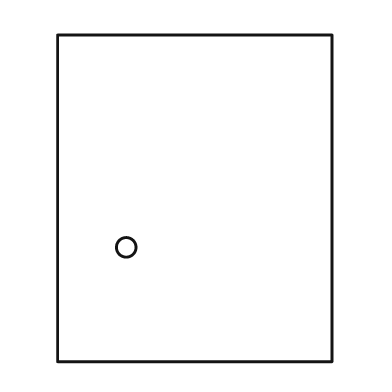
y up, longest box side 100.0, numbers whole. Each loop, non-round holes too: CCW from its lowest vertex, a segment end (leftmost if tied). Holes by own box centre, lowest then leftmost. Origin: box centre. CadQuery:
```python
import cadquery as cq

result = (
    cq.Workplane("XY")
    .moveTo(-42.0, -50.0)
    .lineTo(42.0, -50.0)
    .lineTo(42.0, 50.0)
    .lineTo(-42.0, 50.0)
    .close()
    .moveTo(-21.0, -15.0)
    .circle(3.0)
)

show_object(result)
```